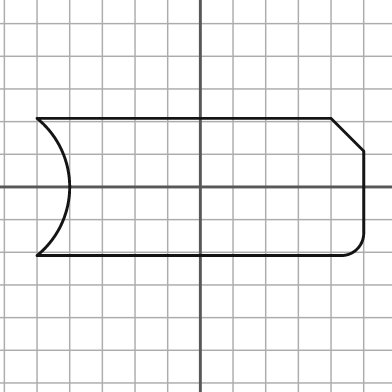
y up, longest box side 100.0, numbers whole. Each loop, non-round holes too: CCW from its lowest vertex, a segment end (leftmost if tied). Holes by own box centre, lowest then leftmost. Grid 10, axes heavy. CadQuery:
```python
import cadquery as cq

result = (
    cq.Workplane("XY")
    .moveTo(-50.0, -21.0)
    .lineTo(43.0, -21.0)
    .threePointArc((48.0, -19.0), (50.0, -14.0))
    .lineTo(50.0, 11.0)
    .lineTo(40.0, 21.0)
    .lineTo(-50.0, 21.0)
    .threePointArc((-40.0, 0.0), (-50.0, -21.0))
    .close()
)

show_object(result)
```